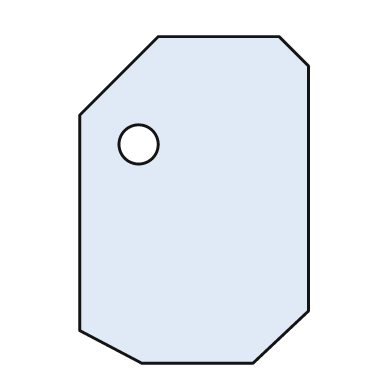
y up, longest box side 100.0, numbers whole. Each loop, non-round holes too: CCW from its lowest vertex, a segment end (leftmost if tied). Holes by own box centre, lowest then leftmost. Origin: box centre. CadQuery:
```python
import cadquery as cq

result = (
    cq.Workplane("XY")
    .moveTo(-16.0, -50.0)
    .lineTo(18.0, -50.0)
    .lineTo(35.0, -34.0)
    .lineTo(35.0, 41.0)
    .lineTo(26.0, 50.0)
    .lineTo(-11.0, 50.0)
    .lineTo(-35.0, 26.0)
    .lineTo(-35.0, -40.0)
    .close()
    .moveTo(-17.0, 17.0)
    .circle(6.0)
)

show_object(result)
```